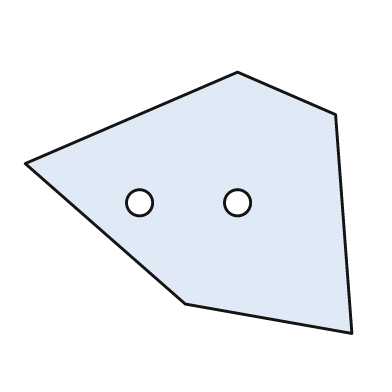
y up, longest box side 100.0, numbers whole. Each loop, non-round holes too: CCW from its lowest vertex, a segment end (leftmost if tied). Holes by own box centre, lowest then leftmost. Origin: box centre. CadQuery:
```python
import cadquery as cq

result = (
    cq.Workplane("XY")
    .moveTo(50.0, -40.0)
    .lineTo(45.0, 27.0)
    .lineTo(15.0, 40.0)
    .lineTo(-50.0, 12.0)
    .lineTo(-1.0, -31.0)
    .close()
    .moveTo(-15.0, 0.0)
    .circle(4.0)
    .moveTo(15.0, 0.0)
    .circle(4.0)
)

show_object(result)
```